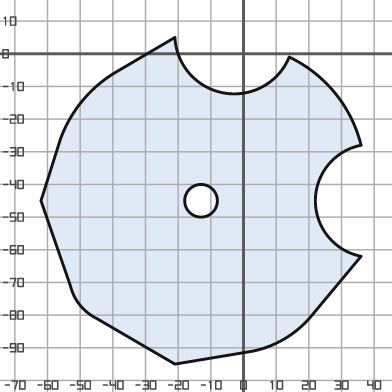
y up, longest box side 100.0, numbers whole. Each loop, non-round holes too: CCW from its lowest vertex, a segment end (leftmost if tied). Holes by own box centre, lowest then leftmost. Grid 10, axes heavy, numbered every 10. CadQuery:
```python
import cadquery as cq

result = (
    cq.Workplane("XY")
    .moveTo(-21.0, -95.0)
    .lineTo(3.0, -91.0)
    .threePointArc((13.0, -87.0), (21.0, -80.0))
    .lineTo(36.0, -62.0)
    .threePointArc((22.0, -45.0), (36.0, -28.0))
    .threePointArc((28.0, -12.0), (14.0, -1.0))
    .threePointArc((-6.0, -12.0), (-21.0, 5.0))
    .lineTo(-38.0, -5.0)
    .threePointArc((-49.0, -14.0), (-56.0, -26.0))
    .lineTo(-62.0, -45.0)
    .lineTo(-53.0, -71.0)
    .threePointArc((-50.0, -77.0), (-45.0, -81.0))
    .close()
    .moveTo(-13.0, -45.0)
    .circle(5.0)
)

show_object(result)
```